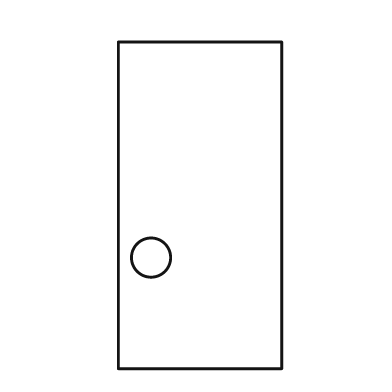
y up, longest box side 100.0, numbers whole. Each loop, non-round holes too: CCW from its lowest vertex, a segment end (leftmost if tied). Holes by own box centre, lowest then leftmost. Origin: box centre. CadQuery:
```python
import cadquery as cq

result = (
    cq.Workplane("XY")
    .moveTo(-25.0, -50.0)
    .lineTo(25.0, -50.0)
    .lineTo(25.0, 50.0)
    .lineTo(-25.0, 50.0)
    .close()
    .moveTo(-15.0, -16.0)
    .circle(6.0)
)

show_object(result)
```